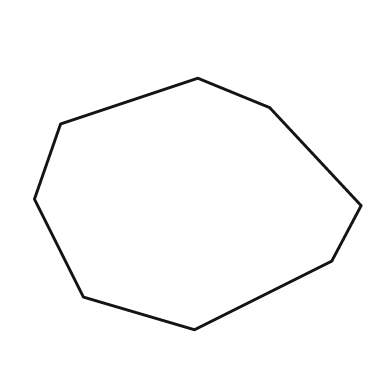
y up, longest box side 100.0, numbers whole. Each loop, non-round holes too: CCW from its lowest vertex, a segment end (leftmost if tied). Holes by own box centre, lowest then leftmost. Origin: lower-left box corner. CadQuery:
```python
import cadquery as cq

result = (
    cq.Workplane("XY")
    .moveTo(49.0, 0.0)
    .lineTo(91.0, 21.0)
    .lineTo(100.0, 38.0)
    .lineTo(72.0, 68.0)
    .lineTo(50.0, 77.0)
    .lineTo(8.0, 63.0)
    .lineTo(0.0, 40.0)
    .lineTo(15.0, 10.0)
    .close()
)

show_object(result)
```